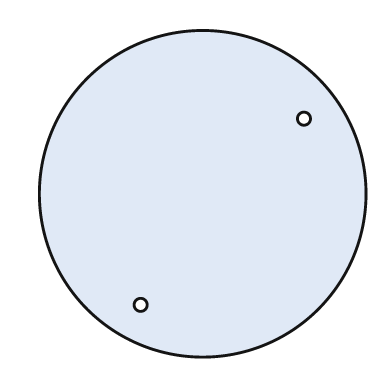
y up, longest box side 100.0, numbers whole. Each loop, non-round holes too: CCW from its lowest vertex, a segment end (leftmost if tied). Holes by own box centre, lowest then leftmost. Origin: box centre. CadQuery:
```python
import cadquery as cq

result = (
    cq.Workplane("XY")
    .moveTo(0.0, 0.0)
    .circle(50.0)
    .moveTo(-19.0, -34.0)
    .circle(2.0)
    .moveTo(31.0, 23.0)
    .circle(2.0)
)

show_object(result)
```